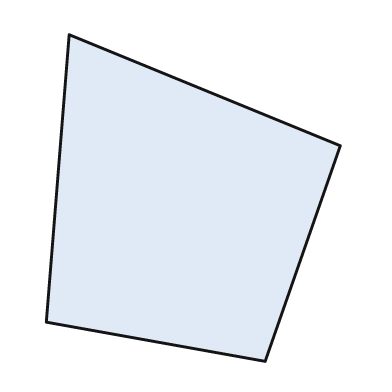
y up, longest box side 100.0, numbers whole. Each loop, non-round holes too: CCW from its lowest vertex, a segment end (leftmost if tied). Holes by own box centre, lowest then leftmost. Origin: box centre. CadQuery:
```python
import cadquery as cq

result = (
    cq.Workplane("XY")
    .moveTo(22.0, -50.0)
    .lineTo(45.0, 16.0)
    .lineTo(-38.0, 50.0)
    .lineTo(-45.0, -38.0)
    .close()
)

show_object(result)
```